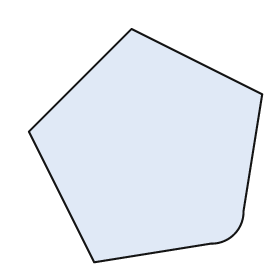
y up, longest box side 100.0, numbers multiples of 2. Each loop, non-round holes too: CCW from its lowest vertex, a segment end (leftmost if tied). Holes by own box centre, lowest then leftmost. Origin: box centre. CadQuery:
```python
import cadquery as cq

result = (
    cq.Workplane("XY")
    .moveTo(-22.0, -50.0)
    .lineTo(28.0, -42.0)
    .threePointArc((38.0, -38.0), (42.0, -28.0))
    .lineTo(50.0, 22.0)
    .lineTo(-6.0, 50.0)
    .lineTo(-50.0, 6.0)
    .close()
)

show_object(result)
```